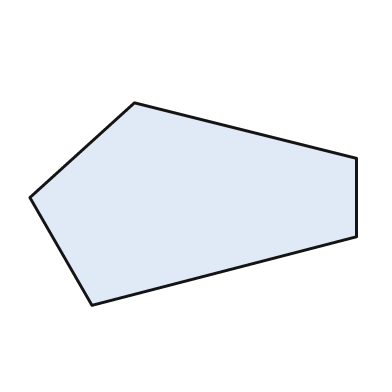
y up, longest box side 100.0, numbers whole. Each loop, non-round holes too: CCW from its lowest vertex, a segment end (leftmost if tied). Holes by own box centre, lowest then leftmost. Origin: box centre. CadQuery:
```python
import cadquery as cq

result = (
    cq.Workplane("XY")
    .moveTo(-31.0, -31.0)
    .lineTo(50.0, -10.0)
    .lineTo(50.0, 14.0)
    .lineTo(-18.0, 31.0)
    .lineTo(-50.0, 2.0)
    .close()
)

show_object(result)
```